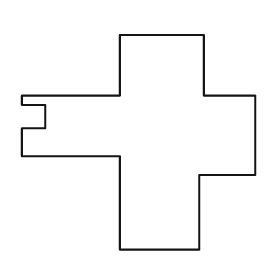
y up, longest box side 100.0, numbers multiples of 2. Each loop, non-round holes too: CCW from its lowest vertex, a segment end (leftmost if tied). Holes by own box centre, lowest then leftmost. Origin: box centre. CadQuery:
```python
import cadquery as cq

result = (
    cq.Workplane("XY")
    .moveTo(-8.0, -46.0)
    .lineTo(26.0, -46.0)
    .lineTo(26.0, -14.0)
    .lineTo(50.0, -14.0)
    .lineTo(50.0, 20.0)
    .lineTo(28.0, 20.0)
    .lineTo(28.0, 46.0)
    .lineTo(-8.0, 46.0)
    .lineTo(-8.0, 20.0)
    .lineTo(-50.0, 20.0)
    .lineTo(-50.0, 16.0)
    .lineTo(-40.0, 16.0)
    .lineTo(-40.0, 6.0)
    .lineTo(-50.0, 6.0)
    .lineTo(-50.0, -6.0)
    .lineTo(-8.0, -6.0)
    .close()
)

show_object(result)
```